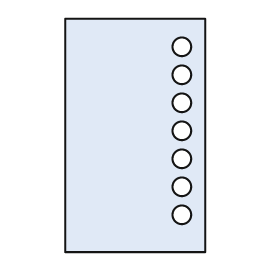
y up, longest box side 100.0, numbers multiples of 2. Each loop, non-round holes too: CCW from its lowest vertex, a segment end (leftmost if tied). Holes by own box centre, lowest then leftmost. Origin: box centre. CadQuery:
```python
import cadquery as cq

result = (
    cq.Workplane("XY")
    .moveTo(-30.0, -50.0)
    .lineTo(30.0, -50.0)
    .lineTo(30.0, 50.0)
    .lineTo(-30.0, 50.0)
    .close()
    .moveTo(20.0, -34.0)
    .circle(4.0)
    .moveTo(20.0, -22.0)
    .circle(4.0)
    .moveTo(20.0, -10.0)
    .circle(4.0)
    .moveTo(20.0, 2.0)
    .circle(4.0)
    .moveTo(20.0, 14.0)
    .circle(4.0)
    .moveTo(20.0, 26.0)
    .circle(4.0)
    .moveTo(20.0, 38.0)
    .circle(4.0)
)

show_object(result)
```